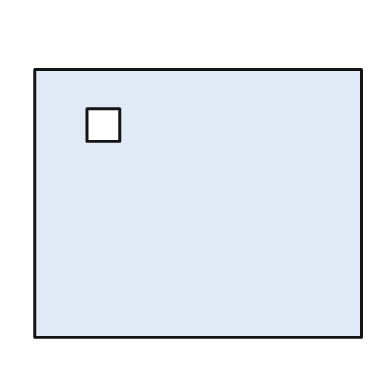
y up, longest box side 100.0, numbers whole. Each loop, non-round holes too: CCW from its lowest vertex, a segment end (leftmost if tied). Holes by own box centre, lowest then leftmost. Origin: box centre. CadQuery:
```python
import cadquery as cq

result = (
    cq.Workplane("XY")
    .moveTo(-50.0, -41.0)
    .lineTo(50.0, -41.0)
    .lineTo(50.0, 41.0)
    .lineTo(-50.0, 41.0)
    .close()
    .moveTo(-34.0, 19.0)
    .lineTo(-24.0, 19.0)
    .lineTo(-24.0, 29.0)
    .lineTo(-34.0, 29.0)
    .close()
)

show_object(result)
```